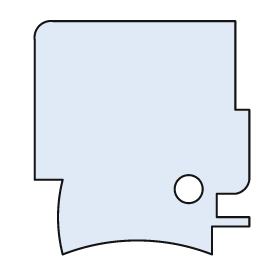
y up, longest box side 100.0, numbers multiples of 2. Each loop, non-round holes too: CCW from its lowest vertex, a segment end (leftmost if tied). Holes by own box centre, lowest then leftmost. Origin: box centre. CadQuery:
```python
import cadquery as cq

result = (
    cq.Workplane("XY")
    .moveTo(-34.0, -50.0)
    .threePointArc((-2.0, -44.0), (30.0, -50.0))
    .lineTo(30.0, -38.0)
    .lineTo(46.0, -38.0)
    .lineTo(46.0, -34.0)
    .lineTo(32.0, -34.0)
    .lineTo(32.0, -24.0)
    .lineTo(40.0, -24.0)
    .threePointArc((44.0, -22.0), (46.0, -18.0))
    .lineTo(46.0, 12.0)
    .lineTo(40.0, 12.0)
    .lineTo(40.0, 50.0)
    .lineTo(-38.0, 50.0)
    .threePointArc((-44.0, 48.0), (-46.0, 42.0))
    .lineTo(-46.0, -18.0)
    .lineTo(-34.0, -18.0)
    .threePointArc((-36.0, -34.0), (-34.0, -50.0))
    .close()
    .moveTo(20.0, -22.0)
    .circle(6.0)
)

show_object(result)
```